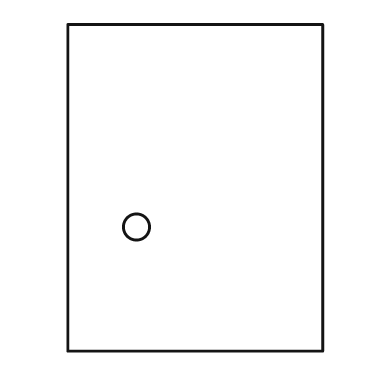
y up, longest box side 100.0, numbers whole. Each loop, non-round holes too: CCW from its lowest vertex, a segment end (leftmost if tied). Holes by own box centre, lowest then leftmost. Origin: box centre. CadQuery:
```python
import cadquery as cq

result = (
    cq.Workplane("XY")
    .moveTo(-39.0, -50.0)
    .lineTo(39.0, -50.0)
    .lineTo(39.0, 50.0)
    .lineTo(-39.0, 50.0)
    .close()
    .moveTo(-18.0, -12.0)
    .circle(4.0)
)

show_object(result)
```